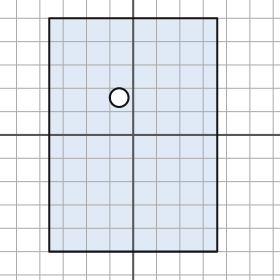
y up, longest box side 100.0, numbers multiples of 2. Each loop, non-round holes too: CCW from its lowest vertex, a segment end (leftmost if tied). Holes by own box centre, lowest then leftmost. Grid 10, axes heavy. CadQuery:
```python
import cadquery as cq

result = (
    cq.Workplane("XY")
    .moveTo(-36.0, -50.0)
    .lineTo(36.0, -50.0)
    .lineTo(36.0, 50.0)
    .lineTo(-36.0, 50.0)
    .close()
    .moveTo(-6.0, 16.0)
    .circle(4.0)
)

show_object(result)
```